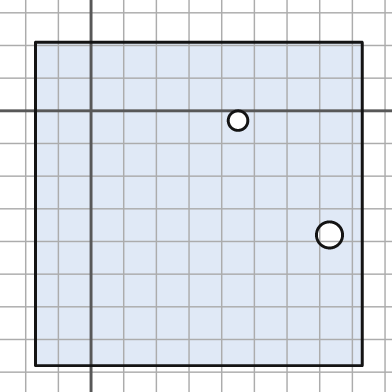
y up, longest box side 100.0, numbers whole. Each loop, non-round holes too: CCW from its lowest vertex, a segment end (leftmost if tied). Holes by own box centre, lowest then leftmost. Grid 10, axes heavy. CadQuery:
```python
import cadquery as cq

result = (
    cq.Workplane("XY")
    .moveTo(-17.0, -78.0)
    .lineTo(83.0, -78.0)
    .lineTo(83.0, 21.0)
    .lineTo(-17.0, 21.0)
    .close()
    .moveTo(73.0, -38.0)
    .circle(4.0)
    .moveTo(45.0, -3.0)
    .circle(3.0)
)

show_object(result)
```